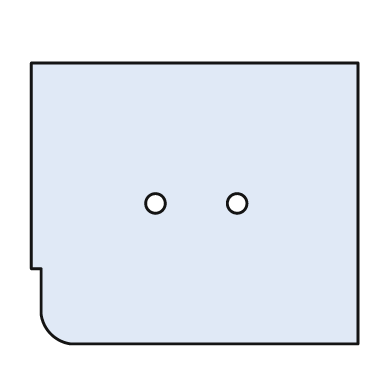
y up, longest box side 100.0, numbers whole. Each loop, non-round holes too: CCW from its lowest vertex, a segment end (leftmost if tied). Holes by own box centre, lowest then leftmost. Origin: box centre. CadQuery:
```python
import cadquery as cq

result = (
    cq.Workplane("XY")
    .moveTo(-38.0, -43.0)
    .lineTo(50.0, -43.0)
    .lineTo(50.0, 43.0)
    .lineTo(-50.0, 43.0)
    .lineTo(-50.0, -20.0)
    .lineTo(-47.0, -20.0)
    .lineTo(-47.0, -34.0)
    .threePointArc((-44.0, -40.0), (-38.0, -43.0))
    .close()
    .moveTo(-12.0, 0.0)
    .circle(3.0)
    .moveTo(13.0, 0.0)
    .circle(3.0)
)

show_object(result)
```